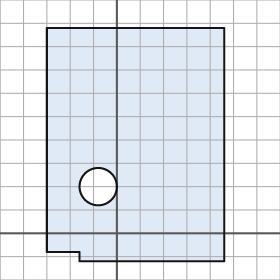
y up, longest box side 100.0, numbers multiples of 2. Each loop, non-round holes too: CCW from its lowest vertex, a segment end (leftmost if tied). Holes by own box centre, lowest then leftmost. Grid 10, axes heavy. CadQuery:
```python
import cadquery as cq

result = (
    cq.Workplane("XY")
    .moveTo(-16.0, -12.0)
    .lineTo(46.0, -12.0)
    .lineTo(46.0, 88.0)
    .lineTo(-30.0, 88.0)
    .lineTo(-30.0, -8.0)
    .lineTo(-16.0, -8.0)
    .close()
    .moveTo(-8.0, 20.0)
    .circle(8.0)
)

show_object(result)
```